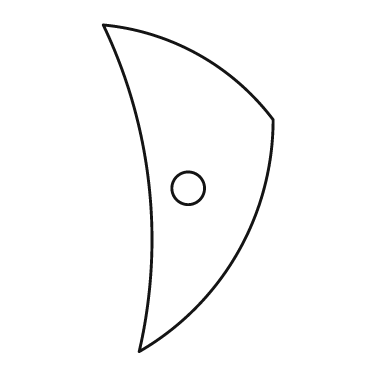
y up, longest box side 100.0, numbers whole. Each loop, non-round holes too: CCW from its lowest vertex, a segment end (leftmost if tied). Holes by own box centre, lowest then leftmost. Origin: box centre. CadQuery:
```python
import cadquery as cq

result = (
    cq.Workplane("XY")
    .moveTo(-15.0, -50.0)
    .threePointArc((15.0, -20.0), (26.0, 21.0))
    .threePointArc((3.0, 41.0), (-26.0, 50.0))
    .threePointArc((-12.0, 1.0), (-15.0, -50.0))
    .close()
    .moveTo(0.0, 0.0)
    .circle(5.0)
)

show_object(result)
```